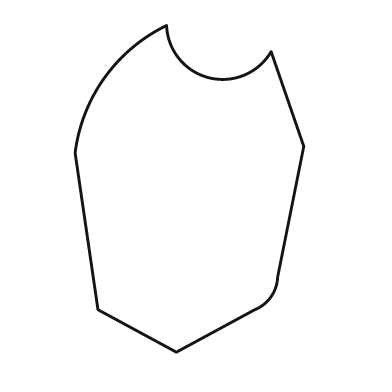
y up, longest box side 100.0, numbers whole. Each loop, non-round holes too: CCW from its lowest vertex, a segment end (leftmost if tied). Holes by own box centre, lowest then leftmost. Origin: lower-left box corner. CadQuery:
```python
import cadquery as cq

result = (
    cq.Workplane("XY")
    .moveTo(31.0, 0.0)
    .lineTo(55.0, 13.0)
    .threePointArc((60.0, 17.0), (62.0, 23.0))
    .lineTo(70.0, 63.0)
    .lineTo(60.0, 92.0)
    .threePointArc((41.0, 84.0), (28.0, 100.0))
    .threePointArc((9.0, 84.0), (0.0, 61.0))
    .lineTo(7.0, 13.0)
    .close()
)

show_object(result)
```